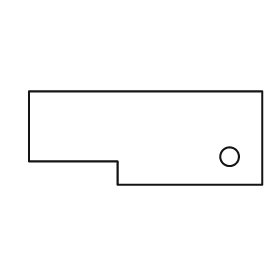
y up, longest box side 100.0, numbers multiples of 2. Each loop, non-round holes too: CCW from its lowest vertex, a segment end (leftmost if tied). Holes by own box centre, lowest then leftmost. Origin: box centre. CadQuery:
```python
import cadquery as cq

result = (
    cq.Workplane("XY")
    .moveTo(-12.0, -20.0)
    .lineTo(50.0, -20.0)
    .lineTo(50.0, 20.0)
    .lineTo(-50.0, 20.0)
    .lineTo(-50.0, -10.0)
    .lineTo(-12.0, -10.0)
    .close()
    .moveTo(36.0, -8.0)
    .circle(4.0)
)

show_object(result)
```